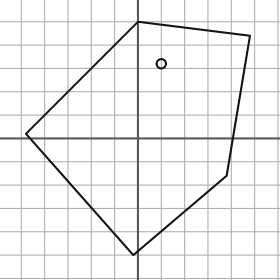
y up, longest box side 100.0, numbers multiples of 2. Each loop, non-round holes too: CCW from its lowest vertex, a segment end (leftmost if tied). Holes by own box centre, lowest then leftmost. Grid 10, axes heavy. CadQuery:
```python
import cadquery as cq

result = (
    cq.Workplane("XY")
    .moveTo(-2.0, -50.0)
    .lineTo(38.0, -16.0)
    .lineTo(48.0, 44.0)
    .lineTo(0.0, 50.0)
    .lineTo(-48.0, 2.0)
    .close()
    .moveTo(10.0, 32.0)
    .circle(2.0)
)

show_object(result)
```